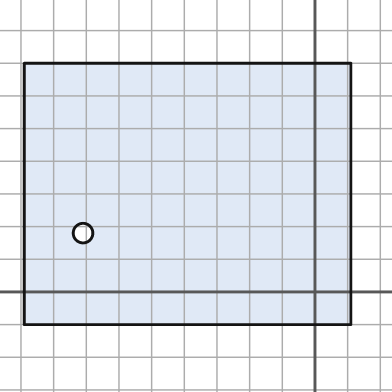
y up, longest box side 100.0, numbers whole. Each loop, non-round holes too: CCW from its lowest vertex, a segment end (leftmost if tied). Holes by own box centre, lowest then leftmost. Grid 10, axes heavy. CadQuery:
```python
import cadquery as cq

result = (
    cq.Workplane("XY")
    .moveTo(-89.0, -10.0)
    .lineTo(11.0, -10.0)
    .lineTo(11.0, 70.0)
    .lineTo(-89.0, 70.0)
    .close()
    .moveTo(-71.0, 18.0)
    .circle(3.0)
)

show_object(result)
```